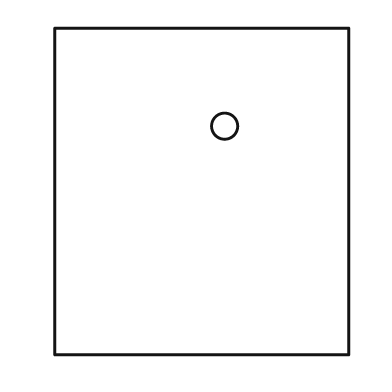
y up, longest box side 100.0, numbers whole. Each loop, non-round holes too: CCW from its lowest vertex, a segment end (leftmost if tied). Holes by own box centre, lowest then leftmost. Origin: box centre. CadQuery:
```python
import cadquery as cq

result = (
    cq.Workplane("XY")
    .moveTo(-45.0, -50.0)
    .lineTo(45.0, -50.0)
    .lineTo(45.0, 50.0)
    .lineTo(-45.0, 50.0)
    .close()
    .moveTo(7.0, 20.0)
    .circle(4.0)
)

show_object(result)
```